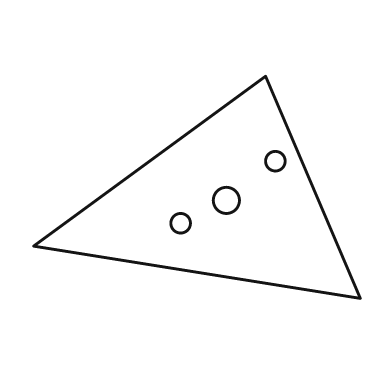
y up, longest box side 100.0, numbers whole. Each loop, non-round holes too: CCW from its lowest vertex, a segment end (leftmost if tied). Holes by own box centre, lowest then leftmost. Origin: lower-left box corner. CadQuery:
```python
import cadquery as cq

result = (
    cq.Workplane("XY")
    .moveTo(100.0, 0.0)
    .lineTo(71.0, 68.0)
    .lineTo(0.0, 16.0)
    .close()
    .moveTo(45.0, 23.0)
    .circle(3.0)
    .moveTo(59.0, 30.0)
    .circle(4.0)
    .moveTo(74.0, 42.0)
    .circle(3.0)
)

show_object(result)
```